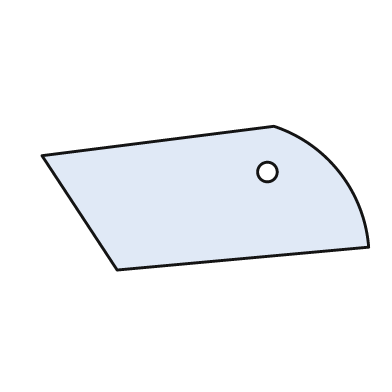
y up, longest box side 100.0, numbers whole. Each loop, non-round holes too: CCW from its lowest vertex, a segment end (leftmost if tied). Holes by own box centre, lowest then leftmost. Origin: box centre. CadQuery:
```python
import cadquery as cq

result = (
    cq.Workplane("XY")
    .moveTo(-27.0, -22.0)
    .lineTo(50.0, -15.0)
    .threePointArc((41.0, 8.0), (21.0, 22.0))
    .lineTo(-50.0, 13.0)
    .close()
    .moveTo(19.0, 8.0)
    .circle(3.0)
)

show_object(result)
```